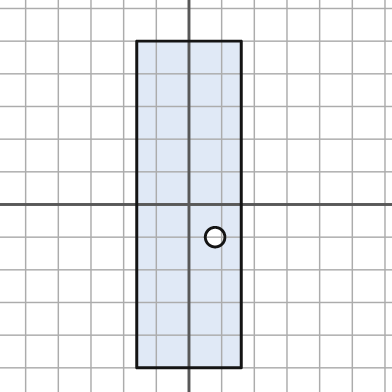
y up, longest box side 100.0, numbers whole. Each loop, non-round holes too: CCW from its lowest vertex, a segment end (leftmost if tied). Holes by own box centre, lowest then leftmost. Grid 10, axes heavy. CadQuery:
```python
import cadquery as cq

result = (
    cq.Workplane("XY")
    .moveTo(-16.0, -50.0)
    .lineTo(16.0, -50.0)
    .lineTo(16.0, 50.0)
    .lineTo(-16.0, 50.0)
    .close()
    .moveTo(8.0, -10.0)
    .circle(3.0)
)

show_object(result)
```